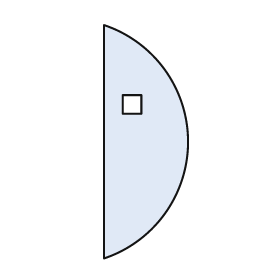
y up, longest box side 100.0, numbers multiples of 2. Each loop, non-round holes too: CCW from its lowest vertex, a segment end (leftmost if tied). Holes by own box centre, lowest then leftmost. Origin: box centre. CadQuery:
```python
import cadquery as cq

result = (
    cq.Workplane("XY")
    .moveTo(-18.0, -50.0)
    .threePointArc((18.0, 0.0), (-18.0, 50.0))
    .close()
    .moveTo(-10.0, 12.0)
    .lineTo(-2.0, 12.0)
    .lineTo(-2.0, 20.0)
    .lineTo(-10.0, 20.0)
    .close()
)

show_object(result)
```